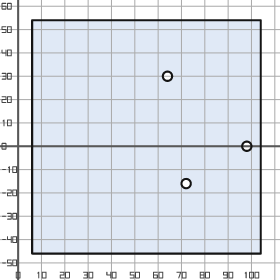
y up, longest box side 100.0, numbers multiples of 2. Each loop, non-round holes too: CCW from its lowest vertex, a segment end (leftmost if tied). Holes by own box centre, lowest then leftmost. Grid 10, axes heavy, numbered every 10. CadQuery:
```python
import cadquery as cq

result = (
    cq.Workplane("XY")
    .moveTo(6.0, -46.0)
    .lineTo(104.0, -46.0)
    .lineTo(104.0, 54.0)
    .lineTo(6.0, 54.0)
    .close()
    .moveTo(72.0, -16.0)
    .circle(2.0)
    .moveTo(98.0, 0.0)
    .circle(2.0)
    .moveTo(64.0, 30.0)
    .circle(2.0)
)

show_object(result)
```